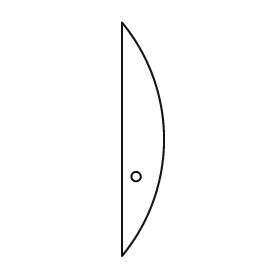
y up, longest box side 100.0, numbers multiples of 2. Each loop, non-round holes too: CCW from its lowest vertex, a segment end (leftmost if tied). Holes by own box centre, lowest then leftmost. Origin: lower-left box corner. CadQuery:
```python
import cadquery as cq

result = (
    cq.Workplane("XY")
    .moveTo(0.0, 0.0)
    .threePointArc((18.0, 50.0), (0.0, 100.0))
    .close()
    .moveTo(6.0, 34.0)
    .circle(2.0)
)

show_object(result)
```